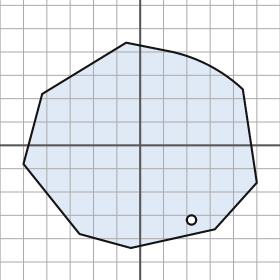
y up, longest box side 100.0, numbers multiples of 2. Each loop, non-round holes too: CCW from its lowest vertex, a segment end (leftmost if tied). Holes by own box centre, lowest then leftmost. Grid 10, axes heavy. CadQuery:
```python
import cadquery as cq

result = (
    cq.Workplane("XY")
    .moveTo(-4.0, -44.0)
    .lineTo(32.0, -36.0)
    .lineTo(50.0, -16.0)
    .lineTo(44.0, 24.0)
    .threePointArc((30.0, 34.0), (14.0, 40.0))
    .lineTo(-6.0, 44.0)
    .lineTo(-42.0, 22.0)
    .lineTo(-50.0, -8.0)
    .lineTo(-26.0, -38.0)
    .close()
    .moveTo(22.0, -32.0)
    .circle(2.0)
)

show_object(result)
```